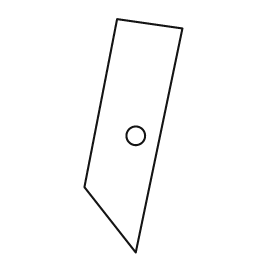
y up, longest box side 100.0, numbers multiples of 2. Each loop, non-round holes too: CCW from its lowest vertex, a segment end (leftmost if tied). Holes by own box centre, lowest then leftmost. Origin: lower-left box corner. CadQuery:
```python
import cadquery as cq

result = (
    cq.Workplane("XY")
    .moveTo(22.0, 0.0)
    .lineTo(42.0, 96.0)
    .lineTo(14.0, 100.0)
    .lineTo(0.0, 28.0)
    .close()
    .moveTo(22.0, 50.0)
    .circle(4.0)
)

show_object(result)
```